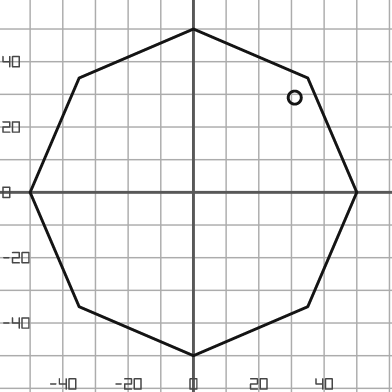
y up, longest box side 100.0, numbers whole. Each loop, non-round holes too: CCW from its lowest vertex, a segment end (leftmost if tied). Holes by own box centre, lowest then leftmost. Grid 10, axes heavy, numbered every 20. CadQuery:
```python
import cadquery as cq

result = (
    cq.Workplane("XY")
    .moveTo(0.0, -50.0)
    .lineTo(35.0, -35.0)
    .lineTo(50.0, 0.0)
    .lineTo(35.0, 35.0)
    .lineTo(0.0, 50.0)
    .lineTo(-35.0, 35.0)
    .lineTo(-50.0, 0.0)
    .lineTo(-35.0, -35.0)
    .close()
    .moveTo(31.0, 29.0)
    .circle(2.0)
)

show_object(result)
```